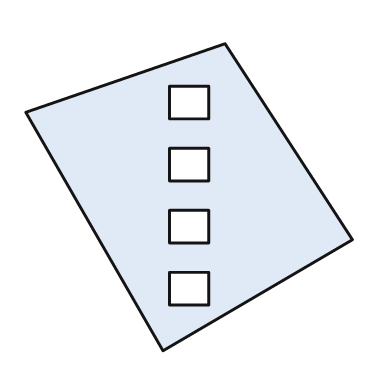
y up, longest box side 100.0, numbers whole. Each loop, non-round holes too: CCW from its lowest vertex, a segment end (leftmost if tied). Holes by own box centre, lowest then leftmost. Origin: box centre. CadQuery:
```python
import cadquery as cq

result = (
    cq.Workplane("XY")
    .moveTo(-8.0, -47.0)
    .lineTo(50.0, -13.0)
    .lineTo(11.0, 47.0)
    .lineTo(-50.0, 26.0)
    .close()
    .moveTo(-6.0, -33.0)
    .lineTo(6.0, -33.0)
    .lineTo(6.0, -23.0)
    .lineTo(-6.0, -23.0)
    .close()
    .moveTo(-6.0, -14.0)
    .lineTo(6.0, -14.0)
    .lineTo(6.0, -4.0)
    .lineTo(-6.0, -4.0)
    .close()
    .moveTo(-6.0, 5.0)
    .lineTo(6.0, 5.0)
    .lineTo(6.0, 15.0)
    .lineTo(-6.0, 15.0)
    .close()
    .moveTo(-6.0, 24.0)
    .lineTo(6.0, 24.0)
    .lineTo(6.0, 34.0)
    .lineTo(-6.0, 34.0)
    .close()
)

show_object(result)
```